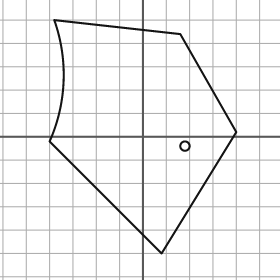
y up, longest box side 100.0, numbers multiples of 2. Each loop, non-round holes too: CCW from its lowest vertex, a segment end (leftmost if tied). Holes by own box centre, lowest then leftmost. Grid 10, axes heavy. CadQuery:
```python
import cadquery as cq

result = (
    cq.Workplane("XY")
    .moveTo(8.0, -50.0)
    .lineTo(40.0, 2.0)
    .lineTo(16.0, 44.0)
    .lineTo(-38.0, 50.0)
    .threePointArc((-34.0, 24.0), (-40.0, -2.0))
    .close()
    .moveTo(18.0, -4.0)
    .circle(2.0)
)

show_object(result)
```